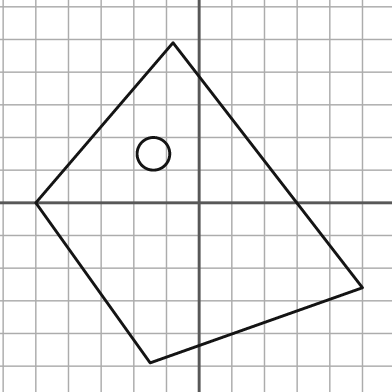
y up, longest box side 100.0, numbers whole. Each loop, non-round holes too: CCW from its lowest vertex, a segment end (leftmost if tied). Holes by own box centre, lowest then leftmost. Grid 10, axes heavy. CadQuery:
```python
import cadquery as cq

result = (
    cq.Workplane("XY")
    .moveTo(-15.0, -49.0)
    .lineTo(50.0, -26.0)
    .lineTo(-8.0, 49.0)
    .lineTo(-50.0, 0.0)
    .close()
    .moveTo(-14.0, 15.0)
    .circle(5.0)
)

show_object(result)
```